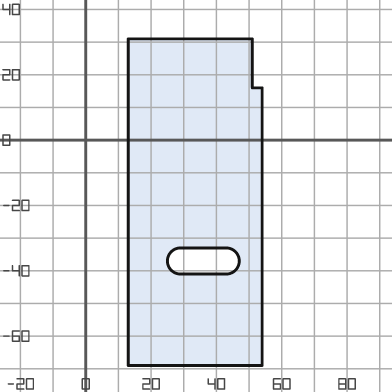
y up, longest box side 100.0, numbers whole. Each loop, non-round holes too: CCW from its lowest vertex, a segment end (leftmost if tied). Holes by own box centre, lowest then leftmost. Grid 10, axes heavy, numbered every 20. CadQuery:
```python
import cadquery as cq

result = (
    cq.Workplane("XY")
    .moveTo(13.0, -69.0)
    .lineTo(54.0, -69.0)
    .lineTo(54.0, 16.0)
    .lineTo(51.0, 16.0)
    .lineTo(51.0, 31.0)
    .lineTo(13.0, 31.0)
    .close()
    .moveTo(29.0, -41.0)
    .lineTo(43.0, -41.0)
    .threePointArc((47.0, -37.0), (43.0, -33.0))
    .lineTo(29.0, -33.0)
    .threePointArc((25.0, -37.0), (29.0, -41.0))
    .close()
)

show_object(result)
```